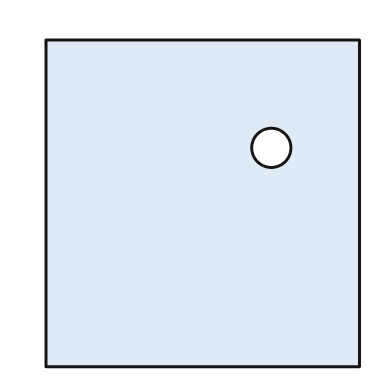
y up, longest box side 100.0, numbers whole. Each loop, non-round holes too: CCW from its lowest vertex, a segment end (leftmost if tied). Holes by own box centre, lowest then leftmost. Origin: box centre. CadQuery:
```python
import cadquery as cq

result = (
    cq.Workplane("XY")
    .moveTo(-48.0, -50.0)
    .lineTo(48.0, -50.0)
    .lineTo(48.0, 50.0)
    .lineTo(-48.0, 50.0)
    .close()
    .moveTo(21.0, 17.0)
    .circle(6.0)
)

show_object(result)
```